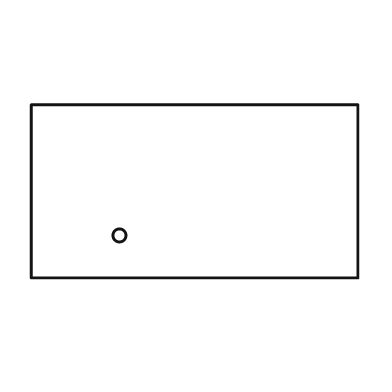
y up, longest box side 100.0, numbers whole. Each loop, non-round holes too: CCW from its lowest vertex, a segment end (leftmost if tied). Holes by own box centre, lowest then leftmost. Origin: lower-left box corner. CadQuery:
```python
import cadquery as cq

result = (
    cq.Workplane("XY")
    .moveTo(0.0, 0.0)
    .lineTo(100.0, 0.0)
    .lineTo(100.0, 53.0)
    .lineTo(0.0, 53.0)
    .close()
    .moveTo(27.0, 13.0)
    .circle(2.0)
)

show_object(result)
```